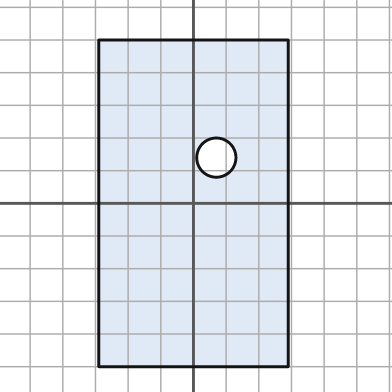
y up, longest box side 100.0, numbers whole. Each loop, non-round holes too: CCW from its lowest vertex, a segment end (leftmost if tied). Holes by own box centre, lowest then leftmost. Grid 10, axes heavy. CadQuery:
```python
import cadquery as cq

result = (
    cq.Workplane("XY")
    .moveTo(-29.0, -50.0)
    .lineTo(29.0, -50.0)
    .lineTo(29.0, 50.0)
    .lineTo(-29.0, 50.0)
    .close()
    .moveTo(7.0, 14.0)
    .circle(6.0)
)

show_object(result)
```